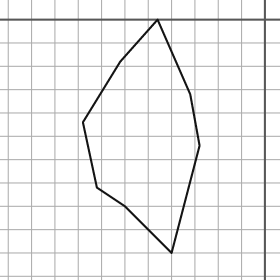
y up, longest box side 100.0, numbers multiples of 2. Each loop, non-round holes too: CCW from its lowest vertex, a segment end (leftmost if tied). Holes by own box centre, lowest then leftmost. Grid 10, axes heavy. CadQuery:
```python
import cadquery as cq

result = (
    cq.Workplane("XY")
    .moveTo(-40.0, -100.0)
    .lineTo(-28.0, -54.0)
    .lineTo(-32.0, -32.0)
    .lineTo(-46.0, 0.0)
    .lineTo(-62.0, -18.0)
    .lineTo(-78.0, -44.0)
    .lineTo(-72.0, -72.0)
    .lineTo(-60.0, -80.0)
    .close()
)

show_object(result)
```